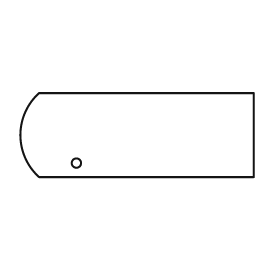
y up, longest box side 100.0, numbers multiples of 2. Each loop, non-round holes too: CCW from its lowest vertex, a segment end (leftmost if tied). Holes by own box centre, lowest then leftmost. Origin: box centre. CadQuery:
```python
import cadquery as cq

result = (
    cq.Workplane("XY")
    .moveTo(-42.0, -18.0)
    .lineTo(50.0, -18.0)
    .lineTo(50.0, 18.0)
    .lineTo(-42.0, 18.0)
    .threePointArc((-50.0, 0.0), (-42.0, -18.0))
    .close()
    .moveTo(-26.0, -12.0)
    .circle(2.0)
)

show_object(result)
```